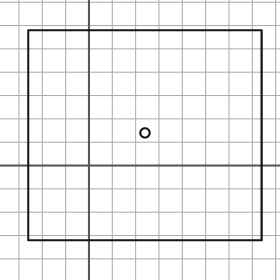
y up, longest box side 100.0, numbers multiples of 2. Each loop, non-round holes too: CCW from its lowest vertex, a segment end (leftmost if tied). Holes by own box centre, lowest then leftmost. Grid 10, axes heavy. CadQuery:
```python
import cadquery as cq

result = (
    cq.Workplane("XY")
    .moveTo(-26.0, -32.0)
    .lineTo(74.0, -32.0)
    .lineTo(74.0, 58.0)
    .lineTo(-26.0, 58.0)
    .close()
    .moveTo(24.0, 14.0)
    .circle(2.0)
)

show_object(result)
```